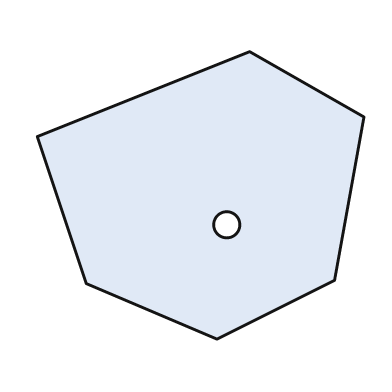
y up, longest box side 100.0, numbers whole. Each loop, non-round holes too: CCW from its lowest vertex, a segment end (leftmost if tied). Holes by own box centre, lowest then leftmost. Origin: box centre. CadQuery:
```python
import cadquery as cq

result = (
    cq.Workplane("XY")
    .moveTo(5.0, -44.0)
    .lineTo(41.0, -26.0)
    .lineTo(50.0, 24.0)
    .lineTo(15.0, 44.0)
    .lineTo(-50.0, 18.0)
    .lineTo(-35.0, -27.0)
    .close()
    .moveTo(8.0, -9.0)
    .circle(4.0)
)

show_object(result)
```